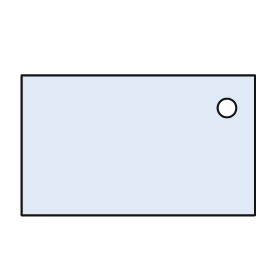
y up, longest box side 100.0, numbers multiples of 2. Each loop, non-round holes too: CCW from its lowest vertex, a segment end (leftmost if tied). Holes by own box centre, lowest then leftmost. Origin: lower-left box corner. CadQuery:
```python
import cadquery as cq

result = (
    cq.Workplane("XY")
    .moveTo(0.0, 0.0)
    .lineTo(100.0, 0.0)
    .lineTo(100.0, 60.0)
    .lineTo(0.0, 60.0)
    .close()
    .moveTo(88.0, 46.0)
    .circle(4.0)
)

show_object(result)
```